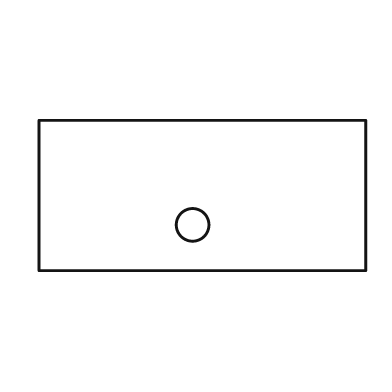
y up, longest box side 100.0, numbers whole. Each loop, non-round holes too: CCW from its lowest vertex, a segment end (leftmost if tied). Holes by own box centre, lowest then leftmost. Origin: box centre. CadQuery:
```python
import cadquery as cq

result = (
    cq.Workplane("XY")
    .moveTo(-50.0, -23.0)
    .lineTo(50.0, -23.0)
    .lineTo(50.0, 23.0)
    .lineTo(-50.0, 23.0)
    .close()
    .moveTo(-3.0, -9.0)
    .circle(5.0)
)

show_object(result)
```